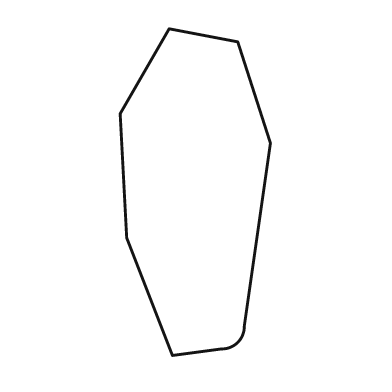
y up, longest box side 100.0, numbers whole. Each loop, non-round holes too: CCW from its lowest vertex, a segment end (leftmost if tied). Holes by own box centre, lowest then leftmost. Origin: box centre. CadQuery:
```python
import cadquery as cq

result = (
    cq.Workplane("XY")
    .moveTo(-7.0, -50.0)
    .lineTo(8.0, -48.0)
    .threePointArc((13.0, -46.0), (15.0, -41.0))
    .lineTo(23.0, 15.0)
    .lineTo(13.0, 46.0)
    .lineTo(-8.0, 50.0)
    .lineTo(-23.0, 24.0)
    .lineTo(-21.0, -14.0)
    .close()
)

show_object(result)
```